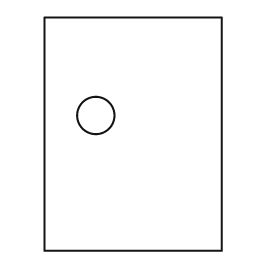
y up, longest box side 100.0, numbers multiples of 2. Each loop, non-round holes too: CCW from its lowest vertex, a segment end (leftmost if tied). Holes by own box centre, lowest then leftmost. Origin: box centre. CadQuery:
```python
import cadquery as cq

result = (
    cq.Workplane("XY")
    .moveTo(-38.0, -50.0)
    .lineTo(38.0, -50.0)
    .lineTo(38.0, 50.0)
    .lineTo(-38.0, 50.0)
    .close()
    .moveTo(-16.0, 8.0)
    .circle(8.0)
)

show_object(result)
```